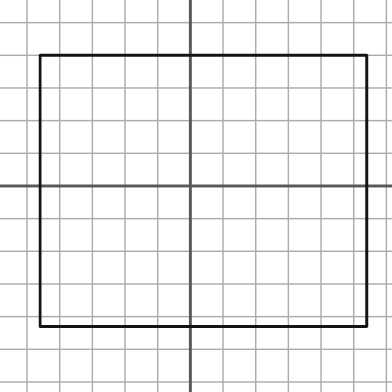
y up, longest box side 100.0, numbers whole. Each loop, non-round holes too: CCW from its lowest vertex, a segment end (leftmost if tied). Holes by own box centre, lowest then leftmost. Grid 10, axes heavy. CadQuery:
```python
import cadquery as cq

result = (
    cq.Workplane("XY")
    .moveTo(-46.0, -43.0)
    .lineTo(54.0, -43.0)
    .lineTo(54.0, 40.0)
    .lineTo(-46.0, 40.0)
    .close()
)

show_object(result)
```